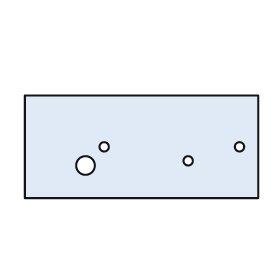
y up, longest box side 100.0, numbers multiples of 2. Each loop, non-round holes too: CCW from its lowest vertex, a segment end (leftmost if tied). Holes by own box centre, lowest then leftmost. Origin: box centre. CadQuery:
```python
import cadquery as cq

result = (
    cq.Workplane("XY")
    .moveTo(-50.0, -22.0)
    .lineTo(50.0, -22.0)
    .lineTo(50.0, 22.0)
    .lineTo(-50.0, 22.0)
    .close()
    .moveTo(-24.0, -8.0)
    .circle(4.0)
    .moveTo(20.0, -6.0)
    .circle(2.0)
    .moveTo(-16.0, 0.0)
    .circle(2.0)
    .moveTo(42.0, 0.0)
    .circle(2.0)
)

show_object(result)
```